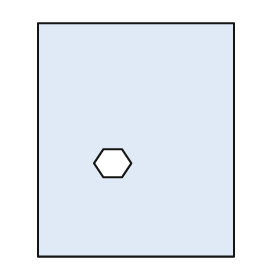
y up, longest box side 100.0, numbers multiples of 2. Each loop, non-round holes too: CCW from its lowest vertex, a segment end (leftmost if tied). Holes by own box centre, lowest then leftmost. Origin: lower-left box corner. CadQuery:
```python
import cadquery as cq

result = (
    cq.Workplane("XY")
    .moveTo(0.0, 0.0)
    .lineTo(84.0, 0.0)
    .lineTo(84.0, 100.0)
    .lineTo(0.0, 100.0)
    .close()
    .moveTo(28.0, 34.0)
    .lineTo(36.0, 34.0)
    .lineTo(40.0, 40.0)
    .lineTo(36.0, 46.0)
    .lineTo(28.0, 46.0)
    .lineTo(24.0, 40.0)
    .close()
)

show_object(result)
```